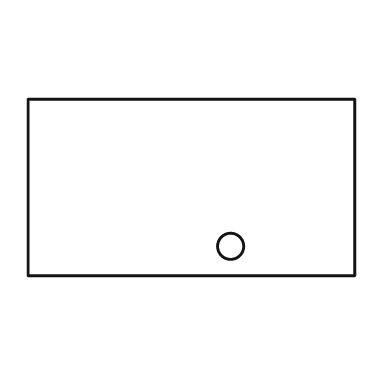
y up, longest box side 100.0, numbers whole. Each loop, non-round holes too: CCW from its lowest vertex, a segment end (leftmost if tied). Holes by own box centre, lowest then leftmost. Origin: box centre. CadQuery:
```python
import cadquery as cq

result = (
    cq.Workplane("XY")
    .moveTo(-50.0, -27.0)
    .lineTo(50.0, -27.0)
    .lineTo(50.0, 27.0)
    .lineTo(-50.0, 27.0)
    .close()
    .moveTo(12.0, -18.0)
    .circle(4.0)
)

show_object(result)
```